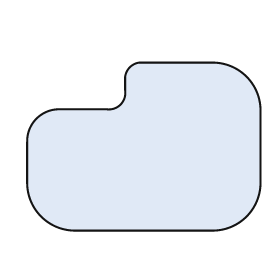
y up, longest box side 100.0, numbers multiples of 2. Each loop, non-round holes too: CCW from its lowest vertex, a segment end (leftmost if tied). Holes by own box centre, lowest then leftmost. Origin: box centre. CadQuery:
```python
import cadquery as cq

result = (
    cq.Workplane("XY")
    .moveTo(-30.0, -36.0)
    .lineTo(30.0, -36.0)
    .threePointArc((44.0, -30.0), (50.0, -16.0))
    .lineTo(50.0, 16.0)
    .threePointArc((44.0, 30.0), (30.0, 36.0))
    .lineTo(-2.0, 36.0)
    .threePointArc((-6.0, 34.0), (-8.0, 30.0))
    .lineTo(-8.0, 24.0)
    .threePointArc((-10.0, 18.0), (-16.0, 16.0))
    .lineTo(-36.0, 16.0)
    .threePointArc((-46.0, 12.0), (-50.0, 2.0))
    .lineTo(-50.0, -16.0)
    .threePointArc((-44.0, -30.0), (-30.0, -36.0))
    .close()
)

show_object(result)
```